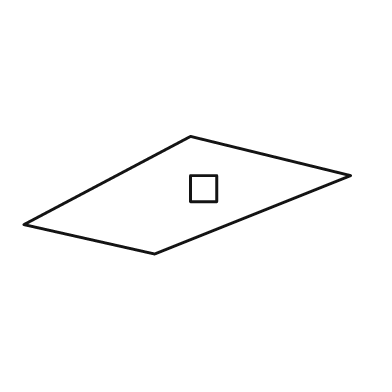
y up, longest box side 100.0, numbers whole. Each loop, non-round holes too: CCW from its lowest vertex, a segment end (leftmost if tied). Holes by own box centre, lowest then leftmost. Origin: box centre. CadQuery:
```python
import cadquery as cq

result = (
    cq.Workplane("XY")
    .moveTo(-10.0, -18.0)
    .lineTo(50.0, 6.0)
    .lineTo(1.0, 18.0)
    .lineTo(-50.0, -9.0)
    .close()
    .moveTo(1.0, -2.0)
    .lineTo(9.0, -2.0)
    .lineTo(9.0, 6.0)
    .lineTo(1.0, 6.0)
    .close()
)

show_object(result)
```